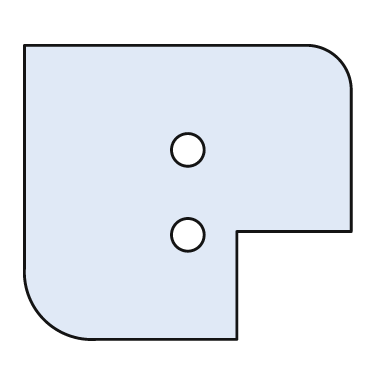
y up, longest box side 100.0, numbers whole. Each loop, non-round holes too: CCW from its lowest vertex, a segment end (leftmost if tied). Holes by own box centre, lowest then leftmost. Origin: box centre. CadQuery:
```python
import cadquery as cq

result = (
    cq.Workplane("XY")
    .moveTo(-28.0, -45.0)
    .lineTo(15.0, -45.0)
    .lineTo(15.0, -12.0)
    .lineTo(50.0, -12.0)
    .lineTo(50.0, 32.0)
    .threePointArc((46.0, 41.0), (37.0, 45.0))
    .lineTo(-50.0, 45.0)
    .lineTo(-50.0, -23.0)
    .threePointArc((-44.0, -39.0), (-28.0, -45.0))
    .close()
    .moveTo(0.0, -13.0)
    .circle(5.0)
    .moveTo(0.0, 13.0)
    .circle(5.0)
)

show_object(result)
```